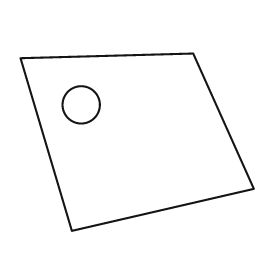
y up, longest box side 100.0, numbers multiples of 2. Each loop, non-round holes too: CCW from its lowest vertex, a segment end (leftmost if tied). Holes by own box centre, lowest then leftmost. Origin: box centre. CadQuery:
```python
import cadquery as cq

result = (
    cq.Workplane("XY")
    .moveTo(-28.0, -38.0)
    .lineTo(50.0, -20.0)
    .lineTo(24.0, 38.0)
    .lineTo(-50.0, 36.0)
    .close()
    .moveTo(-24.0, 16.0)
    .circle(8.0)
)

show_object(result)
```